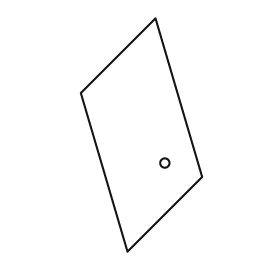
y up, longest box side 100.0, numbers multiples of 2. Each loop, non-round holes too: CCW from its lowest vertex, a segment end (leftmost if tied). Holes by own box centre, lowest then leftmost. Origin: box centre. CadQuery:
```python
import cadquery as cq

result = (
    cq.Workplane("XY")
    .moveTo(-6.0, -50.0)
    .lineTo(26.0, -18.0)
    .lineTo(6.0, 50.0)
    .lineTo(-26.0, 18.0)
    .close()
    .moveTo(10.0, -12.0)
    .circle(2.0)
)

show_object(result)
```